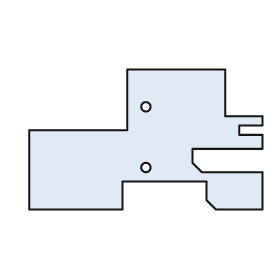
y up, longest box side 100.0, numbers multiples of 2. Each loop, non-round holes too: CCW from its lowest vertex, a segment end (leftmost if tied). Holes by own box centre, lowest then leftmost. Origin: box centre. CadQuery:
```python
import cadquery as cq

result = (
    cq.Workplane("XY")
    .moveTo(-50.0, -30.0)
    .lineTo(-10.0, -30.0)
    .lineTo(-10.0, -18.0)
    .lineTo(26.0, -18.0)
    .lineTo(26.0, -26.0)
    .lineTo(30.0, -30.0)
    .lineTo(50.0, -30.0)
    .lineTo(50.0, -14.0)
    .lineTo(24.0, -14.0)
    .lineTo(20.0, -10.0)
    .lineTo(20.0, -4.0)
    .lineTo(50.0, -4.0)
    .lineTo(50.0, 2.0)
    .lineTo(40.0, 2.0)
    .lineTo(40.0, 6.0)
    .lineTo(50.0, 6.0)
    .lineTo(50.0, 10.0)
    .lineTo(34.0, 10.0)
    .lineTo(34.0, 30.0)
    .lineTo(-8.0, 30.0)
    .lineTo(-8.0, 4.0)
    .lineTo(-50.0, 4.0)
    .close()
    .moveTo(0.0, -12.0)
    .circle(2.0)
    .moveTo(0.0, 14.0)
    .circle(2.0)
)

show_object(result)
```